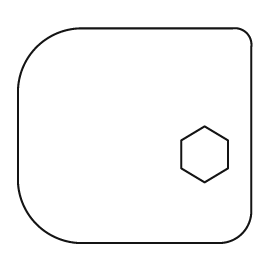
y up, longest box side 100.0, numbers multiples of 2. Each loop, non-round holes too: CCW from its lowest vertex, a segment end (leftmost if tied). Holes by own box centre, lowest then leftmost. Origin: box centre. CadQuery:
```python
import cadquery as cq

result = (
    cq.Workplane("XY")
    .moveTo(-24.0, -46.0)
    .lineTo(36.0, -46.0)
    .threePointArc((46.0, -42.0), (50.0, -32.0))
    .lineTo(50.0, 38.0)
    .threePointArc((48.0, 44.0), (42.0, 46.0))
    .lineTo(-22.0, 46.0)
    .threePointArc((-42.0, 38.0), (-50.0, 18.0))
    .lineTo(-50.0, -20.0)
    .threePointArc((-42.0, -38.0), (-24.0, -46.0))
    .close()
    .moveTo(30.0, -20.0)
    .lineTo(40.0, -14.0)
    .lineTo(40.0, -2.0)
    .lineTo(30.0, 4.0)
    .lineTo(20.0, -2.0)
    .lineTo(20.0, -14.0)
    .close()
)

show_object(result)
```